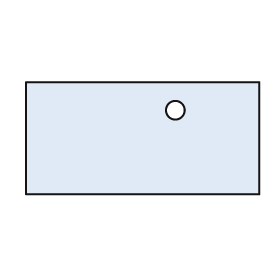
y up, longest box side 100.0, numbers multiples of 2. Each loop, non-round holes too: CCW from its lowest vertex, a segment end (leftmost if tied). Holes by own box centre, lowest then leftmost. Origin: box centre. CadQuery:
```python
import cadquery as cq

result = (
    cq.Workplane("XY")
    .moveTo(-50.0, -24.0)
    .lineTo(50.0, -24.0)
    .lineTo(50.0, 24.0)
    .lineTo(-50.0, 24.0)
    .close()
    .moveTo(14.0, 12.0)
    .circle(4.0)
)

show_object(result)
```